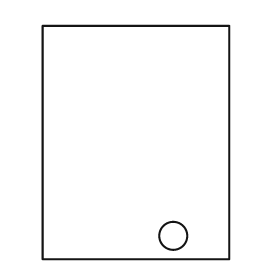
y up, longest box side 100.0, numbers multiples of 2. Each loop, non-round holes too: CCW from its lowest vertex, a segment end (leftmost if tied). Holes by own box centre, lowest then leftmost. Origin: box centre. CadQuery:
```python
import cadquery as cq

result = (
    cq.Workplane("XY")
    .moveTo(-40.0, -50.0)
    .lineTo(40.0, -50.0)
    .lineTo(40.0, 50.0)
    .lineTo(-40.0, 50.0)
    .close()
    .moveTo(16.0, -40.0)
    .circle(6.0)
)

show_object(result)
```